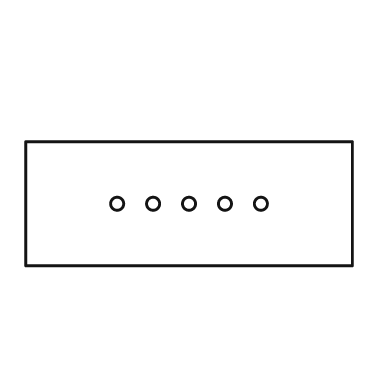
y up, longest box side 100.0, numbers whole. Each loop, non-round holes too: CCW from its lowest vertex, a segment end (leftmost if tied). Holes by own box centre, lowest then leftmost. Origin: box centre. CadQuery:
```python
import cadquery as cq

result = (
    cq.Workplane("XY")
    .moveTo(-50.0, -19.0)
    .lineTo(50.0, -19.0)
    .lineTo(50.0, 19.0)
    .lineTo(-50.0, 19.0)
    .close()
    .moveTo(-22.0, 0.0)
    .circle(2.0)
    .moveTo(-11.0, 0.0)
    .circle(2.0)
    .moveTo(0.0, 0.0)
    .circle(2.0)
    .moveTo(11.0, 0.0)
    .circle(2.0)
    .moveTo(22.0, 0.0)
    .circle(2.0)
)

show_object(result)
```